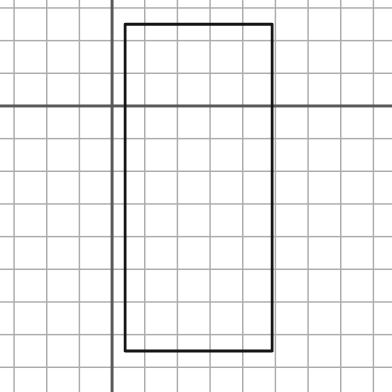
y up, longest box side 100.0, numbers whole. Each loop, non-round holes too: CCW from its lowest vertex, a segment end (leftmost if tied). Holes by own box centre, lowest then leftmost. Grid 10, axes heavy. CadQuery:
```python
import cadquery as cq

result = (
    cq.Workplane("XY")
    .moveTo(4.0, -75.0)
    .lineTo(49.0, -75.0)
    .lineTo(49.0, 25.0)
    .lineTo(4.0, 25.0)
    .close()
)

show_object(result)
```